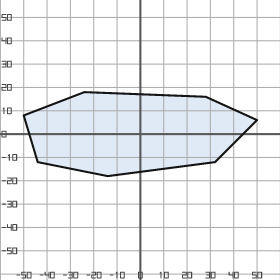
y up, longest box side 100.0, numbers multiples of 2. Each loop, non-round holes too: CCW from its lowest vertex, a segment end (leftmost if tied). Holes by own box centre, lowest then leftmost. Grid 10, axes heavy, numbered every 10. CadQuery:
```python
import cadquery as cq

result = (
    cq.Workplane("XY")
    .moveTo(-14.0, -18.0)
    .lineTo(32.0, -12.0)
    .lineTo(50.0, 6.0)
    .lineTo(28.0, 16.0)
    .lineTo(-24.0, 18.0)
    .lineTo(-50.0, 8.0)
    .lineTo(-44.0, -12.0)
    .close()
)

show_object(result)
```